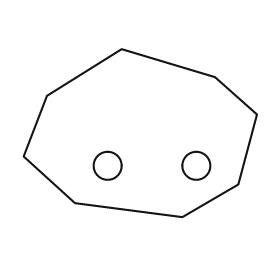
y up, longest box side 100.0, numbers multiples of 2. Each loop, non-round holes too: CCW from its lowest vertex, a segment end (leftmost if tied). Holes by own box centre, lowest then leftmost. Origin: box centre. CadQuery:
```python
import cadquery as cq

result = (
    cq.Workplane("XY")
    .moveTo(18.0, -36.0)
    .lineTo(42.0, -22.0)
    .lineTo(50.0, 8.0)
    .lineTo(32.0, 24.0)
    .lineTo(-8.0, 36.0)
    .lineTo(-40.0, 16.0)
    .lineTo(-50.0, -10.0)
    .lineTo(-28.0, -30.0)
    .close()
    .moveTo(-14.0, -14.0)
    .circle(6.0)
    .moveTo(24.0, -14.0)
    .circle(6.0)
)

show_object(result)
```